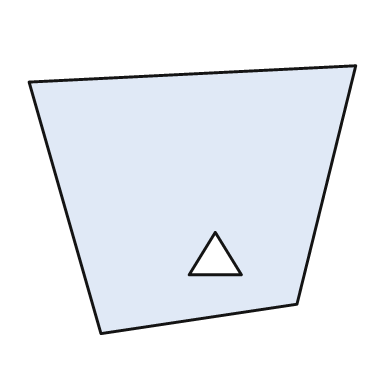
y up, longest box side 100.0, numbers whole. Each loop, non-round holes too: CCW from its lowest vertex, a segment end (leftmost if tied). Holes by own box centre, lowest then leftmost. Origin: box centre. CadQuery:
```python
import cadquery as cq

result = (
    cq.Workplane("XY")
    .moveTo(-28.0, -41.0)
    .lineTo(32.0, -32.0)
    .lineTo(50.0, 41.0)
    .lineTo(-50.0, 36.0)
    .close()
    .moveTo(-1.0, -23.0)
    .lineTo(15.0, -23.0)
    .lineTo(7.0, -10.0)
    .close()
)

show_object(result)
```